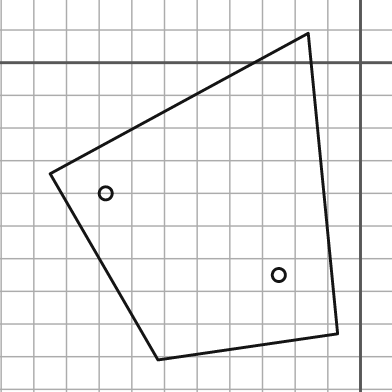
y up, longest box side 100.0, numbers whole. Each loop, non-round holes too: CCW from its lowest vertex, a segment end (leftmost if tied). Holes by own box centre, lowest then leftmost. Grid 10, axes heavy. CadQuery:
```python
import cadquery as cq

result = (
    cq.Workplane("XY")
    .moveTo(-62.0, -91.0)
    .lineTo(-7.0, -83.0)
    .lineTo(-16.0, 9.0)
    .lineTo(-95.0, -34.0)
    .close()
    .moveTo(-25.0, -65.0)
    .circle(2.0)
    .moveTo(-78.0, -40.0)
    .circle(2.0)
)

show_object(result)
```